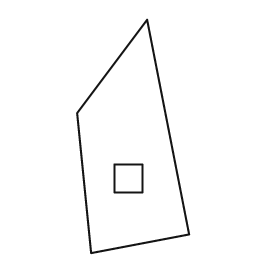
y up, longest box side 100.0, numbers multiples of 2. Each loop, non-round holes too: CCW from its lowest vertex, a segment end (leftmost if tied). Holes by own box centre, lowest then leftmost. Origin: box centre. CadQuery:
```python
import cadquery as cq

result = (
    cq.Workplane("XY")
    .moveTo(-18.0, -50.0)
    .lineTo(24.0, -42.0)
    .lineTo(6.0, 50.0)
    .lineTo(-24.0, 10.0)
    .close()
    .moveTo(-8.0, -24.0)
    .lineTo(4.0, -24.0)
    .lineTo(4.0, -12.0)
    .lineTo(-8.0, -12.0)
    .close()
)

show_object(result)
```